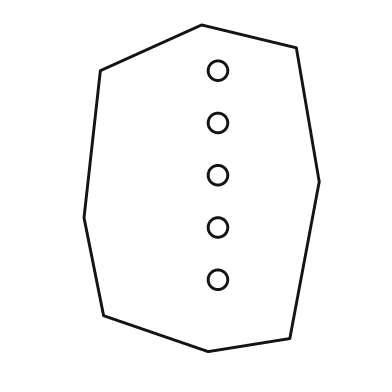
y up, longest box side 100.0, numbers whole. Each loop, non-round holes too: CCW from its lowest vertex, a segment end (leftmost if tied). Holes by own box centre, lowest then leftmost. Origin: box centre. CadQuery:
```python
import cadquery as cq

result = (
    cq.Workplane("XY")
    .moveTo(2.0, -50.0)
    .lineTo(27.0, -46.0)
    .lineTo(36.0, 2.0)
    .lineTo(29.0, 43.0)
    .lineTo(0.0, 50.0)
    .lineTo(-31.0, 36.0)
    .lineTo(-36.0, -9.0)
    .lineTo(-30.0, -39.0)
    .close()
    .moveTo(5.0, -28.0)
    .circle(3.0)
    .moveTo(5.0, -12.0)
    .circle(3.0)
    .moveTo(5.0, 4.0)
    .circle(3.0)
    .moveTo(5.0, 20.0)
    .circle(3.0)
    .moveTo(5.0, 36.0)
    .circle(3.0)
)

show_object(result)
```